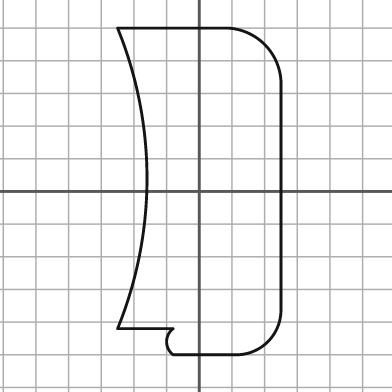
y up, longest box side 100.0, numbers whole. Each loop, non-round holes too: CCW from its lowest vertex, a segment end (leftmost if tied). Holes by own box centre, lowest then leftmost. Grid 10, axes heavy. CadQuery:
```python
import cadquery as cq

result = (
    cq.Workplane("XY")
    .moveTo(-8.0, -50.0)
    .lineTo(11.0, -50.0)
    .threePointArc((21.0, -46.0), (25.0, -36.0))
    .lineTo(25.0, 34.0)
    .threePointArc((20.0, 45.0), (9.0, 50.0))
    .lineTo(-25.0, 50.0)
    .threePointArc((-16.0, 4.0), (-25.0, -42.0))
    .lineTo(-8.0, -42.0)
    .threePointArc((-10.0, -46.0), (-8.0, -50.0))
    .close()
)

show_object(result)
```